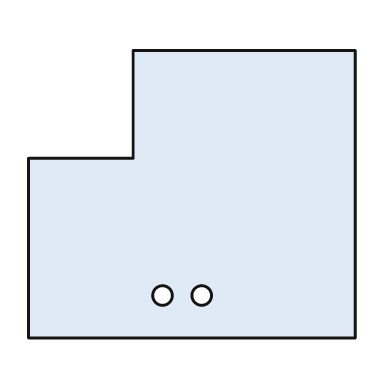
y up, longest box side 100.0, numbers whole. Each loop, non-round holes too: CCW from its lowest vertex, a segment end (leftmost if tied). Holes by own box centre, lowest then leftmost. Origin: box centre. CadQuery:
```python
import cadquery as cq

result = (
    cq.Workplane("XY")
    .moveTo(-50.0, -44.0)
    .lineTo(50.0, -44.0)
    .lineTo(50.0, 44.0)
    .lineTo(-18.0, 44.0)
    .lineTo(-18.0, 11.0)
    .lineTo(-50.0, 11.0)
    .close()
    .moveTo(-9.0, -31.0)
    .circle(3.0)
    .moveTo(3.0, -31.0)
    .circle(3.0)
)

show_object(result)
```